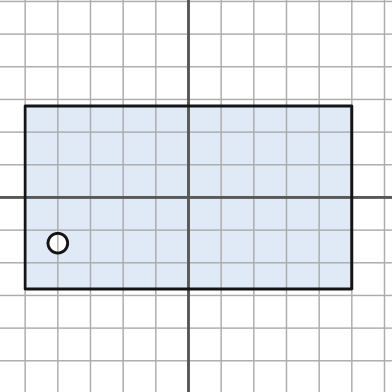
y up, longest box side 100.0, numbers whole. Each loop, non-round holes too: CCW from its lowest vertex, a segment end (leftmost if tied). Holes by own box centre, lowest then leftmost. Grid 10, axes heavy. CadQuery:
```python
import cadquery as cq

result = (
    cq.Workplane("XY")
    .moveTo(-50.0, -28.0)
    .lineTo(50.0, -28.0)
    .lineTo(50.0, 28.0)
    .lineTo(-50.0, 28.0)
    .close()
    .moveTo(-40.0, -14.0)
    .circle(3.0)
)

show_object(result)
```